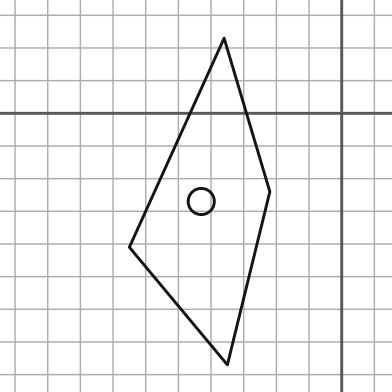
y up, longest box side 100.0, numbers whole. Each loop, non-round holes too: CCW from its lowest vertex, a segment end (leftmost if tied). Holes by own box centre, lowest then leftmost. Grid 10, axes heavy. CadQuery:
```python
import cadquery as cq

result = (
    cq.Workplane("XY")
    .moveTo(-35.0, -77.0)
    .lineTo(-22.0, -24.0)
    .lineTo(-36.0, 23.0)
    .lineTo(-65.0, -41.0)
    .close()
    .moveTo(-43.0, -27.0)
    .circle(4.0)
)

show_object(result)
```